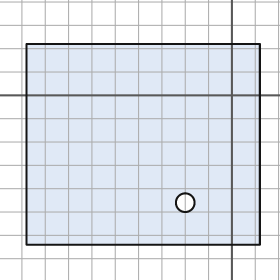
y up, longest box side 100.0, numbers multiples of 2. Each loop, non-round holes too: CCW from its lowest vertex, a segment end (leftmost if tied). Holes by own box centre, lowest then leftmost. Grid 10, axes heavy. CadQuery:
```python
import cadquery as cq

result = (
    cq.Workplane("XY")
    .moveTo(-88.0, -64.0)
    .lineTo(12.0, -64.0)
    .lineTo(12.0, 22.0)
    .lineTo(-88.0, 22.0)
    .close()
    .moveTo(-20.0, -46.0)
    .circle(4.0)
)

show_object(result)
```